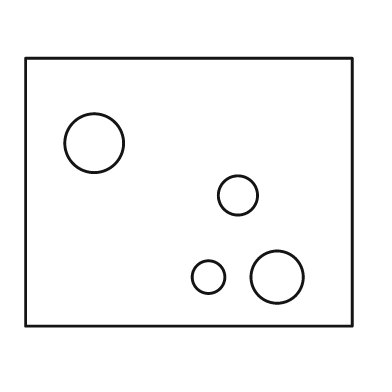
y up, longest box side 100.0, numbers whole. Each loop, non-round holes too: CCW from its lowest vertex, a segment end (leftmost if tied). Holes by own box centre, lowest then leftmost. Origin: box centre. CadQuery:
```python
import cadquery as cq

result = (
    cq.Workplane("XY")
    .moveTo(-50.0, -41.0)
    .lineTo(50.0, -41.0)
    .lineTo(50.0, 41.0)
    .lineTo(-50.0, 41.0)
    .close()
    .moveTo(6.0, -26.0)
    .circle(5.0)
    .moveTo(27.0, -26.0)
    .circle(8.0)
    .moveTo(15.0, -1.0)
    .circle(6.0)
    .moveTo(-29.0, 15.0)
    .circle(9.0)
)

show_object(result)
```